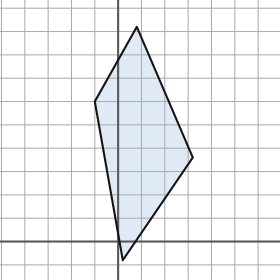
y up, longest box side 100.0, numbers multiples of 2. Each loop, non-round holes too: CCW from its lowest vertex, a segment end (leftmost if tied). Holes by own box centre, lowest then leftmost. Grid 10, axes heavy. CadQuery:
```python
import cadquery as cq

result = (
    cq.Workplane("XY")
    .moveTo(2.0, -8.0)
    .lineTo(32.0, 36.0)
    .lineTo(8.0, 92.0)
    .lineTo(-10.0, 60.0)
    .close()
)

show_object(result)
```